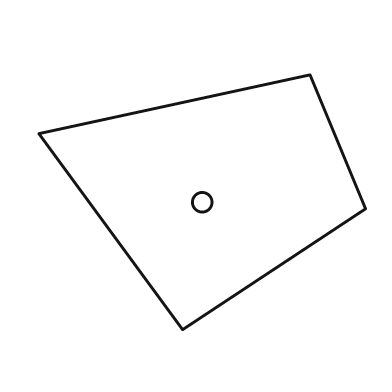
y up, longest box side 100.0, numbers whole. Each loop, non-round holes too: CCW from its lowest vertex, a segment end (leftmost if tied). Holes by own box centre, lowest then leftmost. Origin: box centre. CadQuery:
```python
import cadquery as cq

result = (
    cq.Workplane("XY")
    .moveTo(-6.0, -39.0)
    .lineTo(50.0, -2.0)
    .lineTo(33.0, 39.0)
    .lineTo(-50.0, 21.0)
    .close()
    .moveTo(0.0, 0.0)
    .circle(3.0)
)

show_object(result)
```